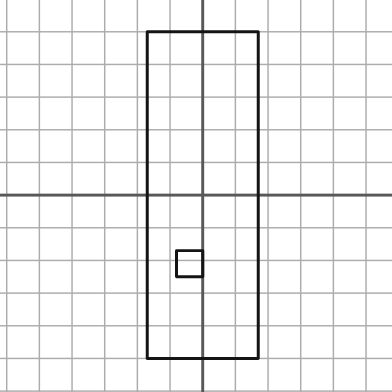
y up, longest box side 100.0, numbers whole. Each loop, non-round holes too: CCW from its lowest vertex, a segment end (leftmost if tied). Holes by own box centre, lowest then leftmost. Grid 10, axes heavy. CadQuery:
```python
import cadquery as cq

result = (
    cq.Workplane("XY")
    .moveTo(-17.0, -50.0)
    .lineTo(17.0, -50.0)
    .lineTo(17.0, 50.0)
    .lineTo(-17.0, 50.0)
    .close()
    .moveTo(-8.0, -25.0)
    .lineTo(0.0, -25.0)
    .lineTo(0.0, -17.0)
    .lineTo(-8.0, -17.0)
    .close()
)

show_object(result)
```